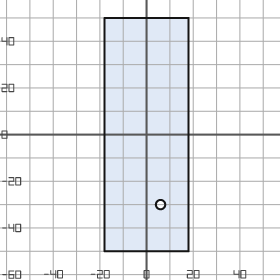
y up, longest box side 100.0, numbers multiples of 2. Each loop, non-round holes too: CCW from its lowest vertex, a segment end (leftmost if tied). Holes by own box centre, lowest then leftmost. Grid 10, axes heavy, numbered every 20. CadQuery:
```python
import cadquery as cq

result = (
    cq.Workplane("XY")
    .moveTo(-18.0, -50.0)
    .lineTo(18.0, -50.0)
    .lineTo(18.0, 50.0)
    .lineTo(-18.0, 50.0)
    .close()
    .moveTo(6.0, -30.0)
    .circle(2.0)
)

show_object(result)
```